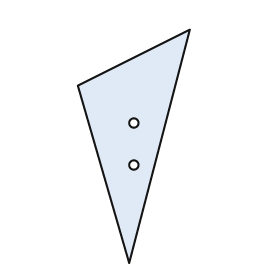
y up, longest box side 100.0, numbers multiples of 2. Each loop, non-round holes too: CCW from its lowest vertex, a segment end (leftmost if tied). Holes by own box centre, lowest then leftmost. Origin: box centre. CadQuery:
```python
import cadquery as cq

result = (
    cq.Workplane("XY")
    .moveTo(-2.0, -50.0)
    .lineTo(24.0, 50.0)
    .lineTo(-24.0, 26.0)
    .close()
    .moveTo(0.0, -8.0)
    .circle(2.0)
    .moveTo(0.0, 10.0)
    .circle(2.0)
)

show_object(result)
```